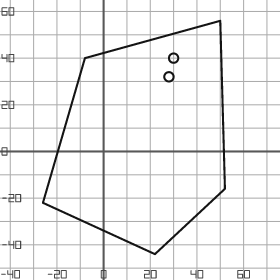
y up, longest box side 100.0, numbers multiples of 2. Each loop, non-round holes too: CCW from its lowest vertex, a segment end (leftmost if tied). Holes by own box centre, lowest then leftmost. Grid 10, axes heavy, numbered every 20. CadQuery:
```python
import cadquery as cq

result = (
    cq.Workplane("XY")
    .moveTo(22.0, -44.0)
    .lineTo(52.0, -16.0)
    .lineTo(50.0, 56.0)
    .lineTo(-8.0, 40.0)
    .lineTo(-26.0, -22.0)
    .close()
    .moveTo(28.0, 32.0)
    .circle(2.0)
    .moveTo(30.0, 40.0)
    .circle(2.0)
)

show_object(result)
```